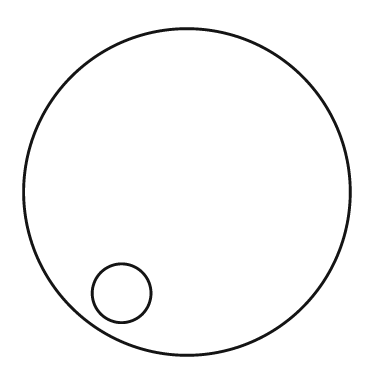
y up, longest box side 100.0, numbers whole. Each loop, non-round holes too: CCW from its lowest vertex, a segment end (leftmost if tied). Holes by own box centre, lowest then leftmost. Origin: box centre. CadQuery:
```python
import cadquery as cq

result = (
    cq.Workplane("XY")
    .moveTo(0.0, 0.0)
    .circle(50.0)
    .moveTo(-20.0, -31.0)
    .circle(9.0)
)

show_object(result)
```